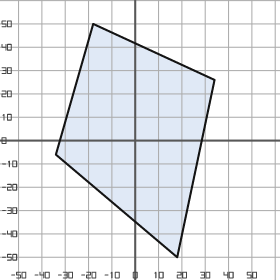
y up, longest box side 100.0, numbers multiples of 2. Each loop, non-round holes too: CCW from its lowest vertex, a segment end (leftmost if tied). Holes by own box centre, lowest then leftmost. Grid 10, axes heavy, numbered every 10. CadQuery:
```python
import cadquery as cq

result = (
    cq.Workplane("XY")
    .moveTo(18.0, -50.0)
    .lineTo(34.0, 26.0)
    .lineTo(-18.0, 50.0)
    .lineTo(-34.0, -6.0)
    .close()
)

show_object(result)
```